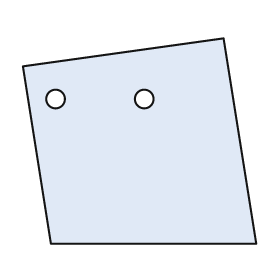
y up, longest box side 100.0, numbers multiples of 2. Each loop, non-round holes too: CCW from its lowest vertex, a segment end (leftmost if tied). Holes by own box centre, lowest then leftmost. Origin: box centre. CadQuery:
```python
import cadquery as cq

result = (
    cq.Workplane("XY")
    .moveTo(-38.0, -44.0)
    .lineTo(50.0, -44.0)
    .lineTo(36.0, 44.0)
    .lineTo(-50.0, 32.0)
    .close()
    .moveTo(-36.0, 18.0)
    .circle(4.0)
    .moveTo(2.0, 18.0)
    .circle(4.0)
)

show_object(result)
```